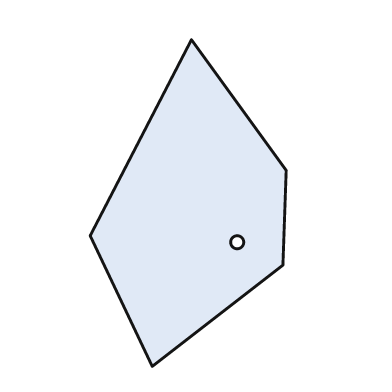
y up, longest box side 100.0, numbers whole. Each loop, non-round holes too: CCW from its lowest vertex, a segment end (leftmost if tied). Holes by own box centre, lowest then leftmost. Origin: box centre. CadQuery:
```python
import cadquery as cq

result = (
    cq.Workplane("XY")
    .moveTo(-11.0, -50.0)
    .lineTo(29.0, -19.0)
    .lineTo(30.0, 10.0)
    .lineTo(1.0, 50.0)
    .lineTo(-30.0, -10.0)
    .close()
    .moveTo(15.0, -12.0)
    .circle(2.0)
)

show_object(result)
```